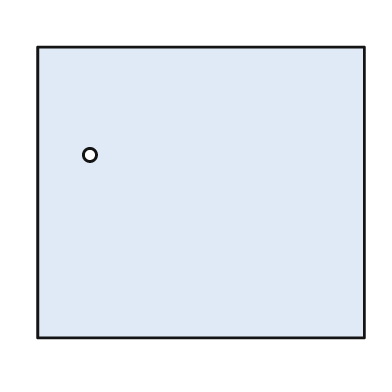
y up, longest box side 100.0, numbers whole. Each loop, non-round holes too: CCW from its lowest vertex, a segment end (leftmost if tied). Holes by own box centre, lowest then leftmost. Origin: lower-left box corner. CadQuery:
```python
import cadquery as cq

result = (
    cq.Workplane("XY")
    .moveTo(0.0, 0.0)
    .lineTo(100.0, 0.0)
    .lineTo(100.0, 89.0)
    .lineTo(0.0, 89.0)
    .close()
    .moveTo(16.0, 56.0)
    .circle(2.0)
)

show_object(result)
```